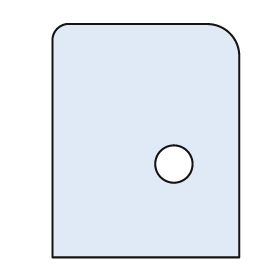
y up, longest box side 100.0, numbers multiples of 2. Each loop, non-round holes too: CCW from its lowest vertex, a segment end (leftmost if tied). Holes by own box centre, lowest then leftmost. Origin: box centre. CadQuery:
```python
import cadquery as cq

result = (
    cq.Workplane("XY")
    .moveTo(-40.0, -50.0)
    .lineTo(40.0, -50.0)
    .lineTo(40.0, 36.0)
    .threePointArc((36.0, 46.0), (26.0, 50.0))
    .lineTo(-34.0, 50.0)
    .threePointArc((-38.0, 48.0), (-40.0, 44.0))
    .close()
    .moveTo(12.0, -10.0)
    .circle(8.0)
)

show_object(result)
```